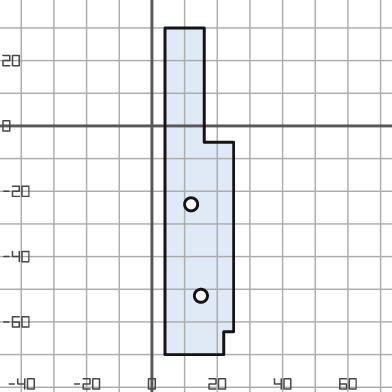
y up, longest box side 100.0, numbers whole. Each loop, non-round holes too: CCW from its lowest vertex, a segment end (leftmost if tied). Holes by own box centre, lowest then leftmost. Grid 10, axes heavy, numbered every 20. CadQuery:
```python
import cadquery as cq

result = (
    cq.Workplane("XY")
    .moveTo(4.0, -70.0)
    .lineTo(22.0, -70.0)
    .lineTo(22.0, -63.0)
    .lineTo(25.0, -63.0)
    .lineTo(25.0, -5.0)
    .lineTo(16.0, -5.0)
    .lineTo(16.0, 30.0)
    .lineTo(4.0, 30.0)
    .close()
    .moveTo(15.0, -52.0)
    .circle(2.0)
    .moveTo(12.0, -24.0)
    .circle(2.0)
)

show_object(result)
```